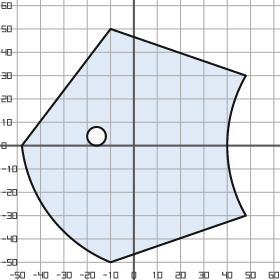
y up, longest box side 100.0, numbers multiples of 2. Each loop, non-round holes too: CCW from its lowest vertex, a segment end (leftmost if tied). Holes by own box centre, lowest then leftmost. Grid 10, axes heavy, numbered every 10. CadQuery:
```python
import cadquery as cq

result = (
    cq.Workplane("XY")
    .moveTo(-10.0, -50.0)
    .lineTo(48.0, -30.0)
    .threePointArc((40.0, 0.0), (48.0, 30.0))
    .lineTo(-10.0, 50.0)
    .lineTo(-48.0, 0.0)
    .threePointArc((-36.0, -30.0), (-10.0, -50.0))
    .close()
    .moveTo(-16.0, 4.0)
    .circle(4.0)
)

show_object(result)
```